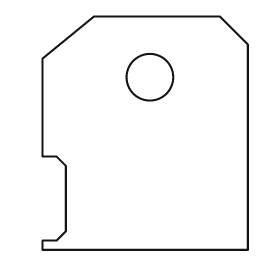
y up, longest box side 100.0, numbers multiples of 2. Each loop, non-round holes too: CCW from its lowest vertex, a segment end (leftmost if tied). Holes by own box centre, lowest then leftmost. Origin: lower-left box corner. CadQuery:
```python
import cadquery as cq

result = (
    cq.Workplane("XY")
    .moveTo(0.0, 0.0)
    .lineTo(88.0, 0.0)
    .lineTo(88.0, 88.0)
    .lineTo(76.0, 100.0)
    .lineTo(22.0, 100.0)
    .lineTo(0.0, 82.0)
    .lineTo(0.0, 40.0)
    .lineTo(6.0, 40.0)
    .lineTo(10.0, 36.0)
    .lineTo(10.0, 8.0)
    .lineTo(6.0, 4.0)
    .lineTo(0.0, 4.0)
    .close()
    .moveTo(46.0, 74.0)
    .circle(10.0)
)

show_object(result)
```